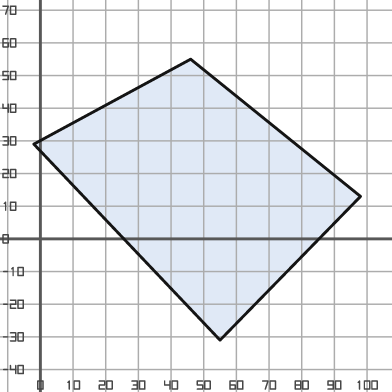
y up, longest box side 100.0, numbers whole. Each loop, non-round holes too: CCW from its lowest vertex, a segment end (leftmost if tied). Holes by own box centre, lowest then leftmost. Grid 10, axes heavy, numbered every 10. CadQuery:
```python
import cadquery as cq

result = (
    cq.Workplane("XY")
    .moveTo(55.0, -31.0)
    .lineTo(98.0, 13.0)
    .lineTo(46.0, 55.0)
    .lineTo(-2.0, 29.0)
    .close()
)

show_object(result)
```